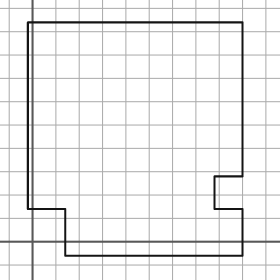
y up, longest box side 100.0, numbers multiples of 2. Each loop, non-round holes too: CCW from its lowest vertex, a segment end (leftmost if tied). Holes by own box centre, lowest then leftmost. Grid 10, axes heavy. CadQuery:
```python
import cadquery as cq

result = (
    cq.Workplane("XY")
    .moveTo(14.0, -6.0)
    .lineTo(90.0, -6.0)
    .lineTo(90.0, 14.0)
    .lineTo(78.0, 14.0)
    .lineTo(78.0, 28.0)
    .lineTo(90.0, 28.0)
    .lineTo(90.0, 94.0)
    .lineTo(-2.0, 94.0)
    .lineTo(-2.0, 14.0)
    .lineTo(14.0, 14.0)
    .close()
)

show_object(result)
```